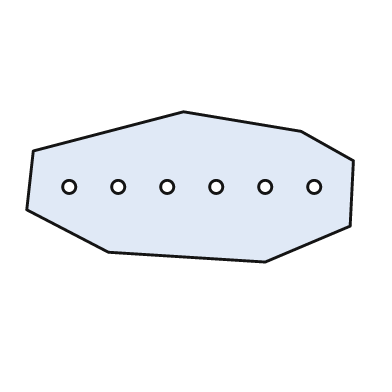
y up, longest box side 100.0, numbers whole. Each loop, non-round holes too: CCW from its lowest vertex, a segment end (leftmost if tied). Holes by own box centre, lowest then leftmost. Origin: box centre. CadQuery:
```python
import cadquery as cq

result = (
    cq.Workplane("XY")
    .moveTo(23.0, -23.0)
    .lineTo(49.0, -12.0)
    .lineTo(50.0, 8.0)
    .lineTo(34.0, 17.0)
    .lineTo(-2.0, 23.0)
    .lineTo(-48.0, 11.0)
    .lineTo(-50.0, -7.0)
    .lineTo(-25.0, -20.0)
    .close()
    .moveTo(-37.0, 0.0)
    .circle(2.0)
    .moveTo(-22.0, 0.0)
    .circle(2.0)
    .moveTo(-7.0, 0.0)
    .circle(2.0)
    .moveTo(8.0, 0.0)
    .circle(2.0)
    .moveTo(23.0, 0.0)
    .circle(2.0)
    .moveTo(38.0, 0.0)
    .circle(2.0)
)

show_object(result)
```